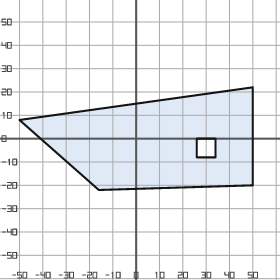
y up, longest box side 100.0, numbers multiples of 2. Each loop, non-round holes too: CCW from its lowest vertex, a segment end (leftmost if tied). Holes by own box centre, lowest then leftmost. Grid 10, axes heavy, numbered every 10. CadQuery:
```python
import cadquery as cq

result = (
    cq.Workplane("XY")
    .moveTo(-16.0, -22.0)
    .lineTo(50.0, -20.0)
    .lineTo(50.0, 22.0)
    .lineTo(-50.0, 8.0)
    .close()
    .moveTo(26.0, -8.0)
    .lineTo(34.0, -8.0)
    .lineTo(34.0, 0.0)
    .lineTo(26.0, 0.0)
    .close()
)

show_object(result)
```